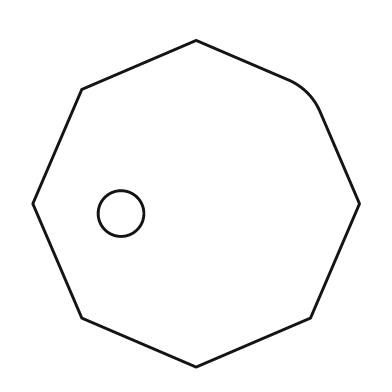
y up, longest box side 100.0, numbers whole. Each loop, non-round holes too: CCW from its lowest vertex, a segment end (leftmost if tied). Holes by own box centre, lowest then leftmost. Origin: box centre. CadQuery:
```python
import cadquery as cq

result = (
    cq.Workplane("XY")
    .moveTo(0.0, -50.0)
    .lineTo(35.0, -35.0)
    .lineTo(50.0, 0.0)
    .lineTo(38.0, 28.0)
    .threePointArc((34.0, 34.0), (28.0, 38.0))
    .lineTo(0.0, 50.0)
    .lineTo(-35.0, 35.0)
    .lineTo(-50.0, 0.0)
    .lineTo(-35.0, -35.0)
    .close()
    .moveTo(-23.0, -3.0)
    .circle(7.0)
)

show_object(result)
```